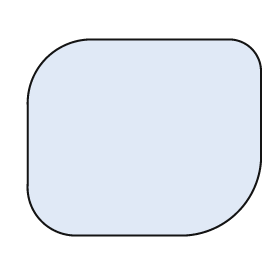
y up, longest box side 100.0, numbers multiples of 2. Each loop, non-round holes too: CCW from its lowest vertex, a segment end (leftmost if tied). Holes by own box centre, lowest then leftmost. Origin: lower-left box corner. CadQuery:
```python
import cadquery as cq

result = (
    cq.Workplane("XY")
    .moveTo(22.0, 0.0)
    .lineTo(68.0, 0.0)
    .threePointArc((90.0, 10.0), (100.0, 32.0))
    .lineTo(100.0, 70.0)
    .threePointArc((96.0, 80.0), (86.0, 84.0))
    .lineTo(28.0, 84.0)
    .threePointArc((8.0, 76.0), (0.0, 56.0))
    .lineTo(0.0, 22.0)
    .threePointArc((6.0, 6.0), (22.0, 0.0))
    .close()
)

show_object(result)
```